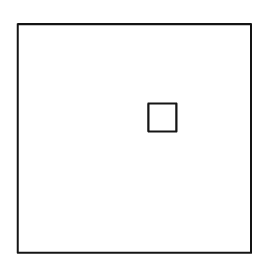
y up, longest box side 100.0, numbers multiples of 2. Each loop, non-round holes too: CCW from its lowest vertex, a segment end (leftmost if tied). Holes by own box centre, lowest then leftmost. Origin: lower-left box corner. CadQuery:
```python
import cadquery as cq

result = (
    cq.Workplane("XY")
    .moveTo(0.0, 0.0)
    .lineTo(100.0, 0.0)
    .lineTo(100.0, 98.0)
    .lineTo(0.0, 98.0)
    .close()
    .moveTo(56.0, 52.0)
    .lineTo(68.0, 52.0)
    .lineTo(68.0, 64.0)
    .lineTo(56.0, 64.0)
    .close()
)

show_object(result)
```